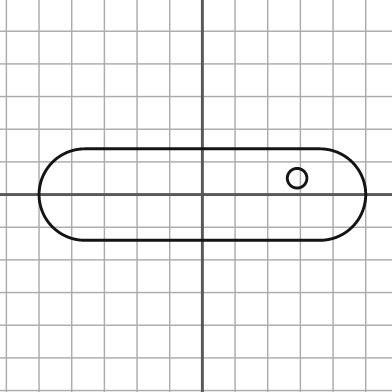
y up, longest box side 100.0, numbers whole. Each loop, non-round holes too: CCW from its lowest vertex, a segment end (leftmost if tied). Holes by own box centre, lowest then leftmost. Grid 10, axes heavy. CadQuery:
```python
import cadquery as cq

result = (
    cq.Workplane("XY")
    .moveTo(-36.0, -14.0)
    .lineTo(36.0, -14.0)
    .threePointArc((50.0, 0.0), (36.0, 14.0))
    .lineTo(-36.0, 14.0)
    .threePointArc((-50.0, 0.0), (-36.0, -14.0))
    .close()
    .moveTo(29.0, 5.0)
    .circle(3.0)
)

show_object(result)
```